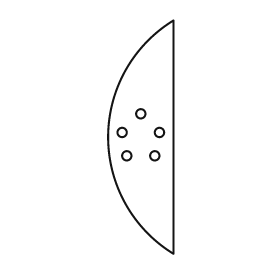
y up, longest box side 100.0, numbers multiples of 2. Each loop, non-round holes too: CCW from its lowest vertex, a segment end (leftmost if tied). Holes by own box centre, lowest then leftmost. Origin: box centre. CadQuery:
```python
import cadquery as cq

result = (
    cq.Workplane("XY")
    .moveTo(14.0, -50.0)
    .lineTo(14.0, 50.0)
    .threePointArc((-14.0, 0.0), (14.0, -50.0))
    .close()
    .moveTo(-6.0, -8.0)
    .circle(2.0)
    .moveTo(6.0, -8.0)
    .circle(2.0)
    .moveTo(-8.0, 2.0)
    .circle(2.0)
    .moveTo(8.0, 2.0)
    .circle(2.0)
    .moveTo(0.0, 10.0)
    .circle(2.0)
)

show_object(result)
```